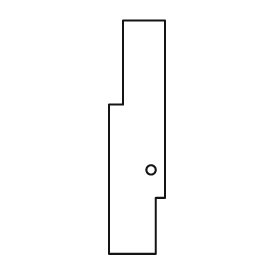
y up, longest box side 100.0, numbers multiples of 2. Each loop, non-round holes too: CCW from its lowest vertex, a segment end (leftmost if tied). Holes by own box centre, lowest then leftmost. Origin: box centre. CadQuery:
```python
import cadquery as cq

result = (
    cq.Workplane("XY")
    .moveTo(-12.0, -50.0)
    .lineTo(8.0, -50.0)
    .lineTo(8.0, -26.0)
    .lineTo(12.0, -26.0)
    .lineTo(12.0, 50.0)
    .lineTo(-6.0, 50.0)
    .lineTo(-6.0, 14.0)
    .lineTo(-12.0, 14.0)
    .close()
    .moveTo(6.0, -14.0)
    .circle(2.0)
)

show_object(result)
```